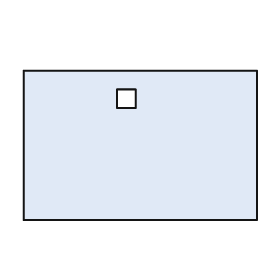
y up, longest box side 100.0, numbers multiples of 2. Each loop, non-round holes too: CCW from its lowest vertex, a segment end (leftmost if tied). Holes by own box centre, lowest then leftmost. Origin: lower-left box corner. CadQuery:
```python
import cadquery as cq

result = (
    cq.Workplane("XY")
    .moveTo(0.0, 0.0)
    .lineTo(100.0, 0.0)
    .lineTo(100.0, 64.0)
    .lineTo(0.0, 64.0)
    .close()
    .moveTo(40.0, 48.0)
    .lineTo(48.0, 48.0)
    .lineTo(48.0, 56.0)
    .lineTo(40.0, 56.0)
    .close()
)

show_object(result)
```